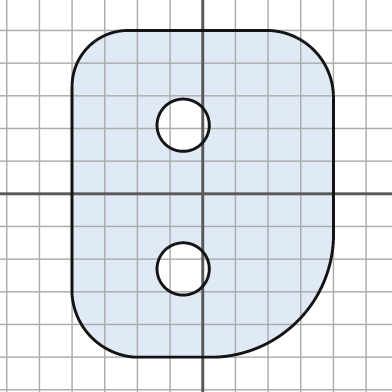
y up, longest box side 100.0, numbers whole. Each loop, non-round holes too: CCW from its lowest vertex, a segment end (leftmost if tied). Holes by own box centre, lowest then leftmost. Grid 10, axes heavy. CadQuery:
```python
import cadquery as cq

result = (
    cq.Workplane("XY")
    .moveTo(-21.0, -50.0)
    .lineTo(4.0, -50.0)
    .threePointArc((29.0, -39.0), (40.0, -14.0))
    .lineTo(40.0, 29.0)
    .threePointArc((34.0, 44.0), (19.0, 50.0))
    .lineTo(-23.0, 50.0)
    .threePointArc((-35.0, 45.0), (-40.0, 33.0))
    .lineTo(-40.0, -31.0)
    .threePointArc((-34.0, -44.0), (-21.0, -50.0))
    .close()
    .moveTo(-6.0, -23.0)
    .circle(8.0)
    .moveTo(-6.0, 21.0)
    .circle(8.0)
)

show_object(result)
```